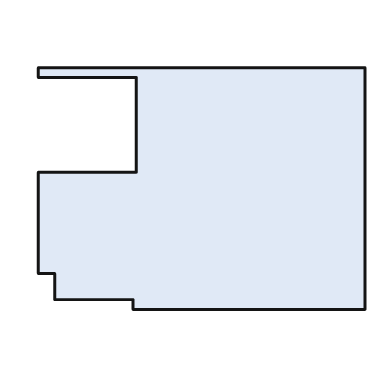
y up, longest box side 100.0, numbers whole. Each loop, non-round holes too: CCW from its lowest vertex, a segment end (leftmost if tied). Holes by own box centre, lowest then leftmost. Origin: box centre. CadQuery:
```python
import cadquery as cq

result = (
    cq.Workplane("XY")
    .moveTo(-21.0, -37.0)
    .lineTo(50.0, -37.0)
    .lineTo(50.0, 37.0)
    .lineTo(-50.0, 37.0)
    .lineTo(-50.0, 34.0)
    .lineTo(-20.0, 34.0)
    .lineTo(-20.0, 5.0)
    .lineTo(-50.0, 5.0)
    .lineTo(-50.0, -26.0)
    .lineTo(-45.0, -26.0)
    .lineTo(-45.0, -34.0)
    .lineTo(-21.0, -34.0)
    .close()
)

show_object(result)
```